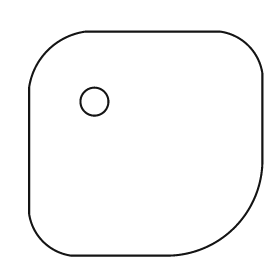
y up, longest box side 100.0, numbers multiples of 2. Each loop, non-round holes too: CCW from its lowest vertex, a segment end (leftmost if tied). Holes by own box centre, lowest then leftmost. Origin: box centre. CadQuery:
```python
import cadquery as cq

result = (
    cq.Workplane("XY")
    .moveTo(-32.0, -48.0)
    .lineTo(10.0, -48.0)
    .threePointArc((38.0, -36.0), (50.0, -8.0))
    .lineTo(50.0, 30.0)
    .threePointArc((44.0, 42.0), (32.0, 48.0))
    .lineTo(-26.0, 48.0)
    .threePointArc((-42.0, 40.0), (-50.0, 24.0))
    .lineTo(-50.0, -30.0)
    .threePointArc((-44.0, -42.0), (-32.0, -48.0))
    .close()
    .moveTo(-22.0, 18.0)
    .circle(6.0)
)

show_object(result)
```